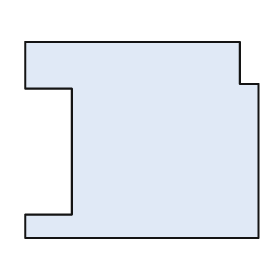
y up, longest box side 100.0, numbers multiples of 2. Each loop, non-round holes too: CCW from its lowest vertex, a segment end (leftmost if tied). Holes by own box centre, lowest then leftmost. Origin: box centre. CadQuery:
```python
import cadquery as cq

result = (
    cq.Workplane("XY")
    .moveTo(-50.0, -42.0)
    .lineTo(50.0, -42.0)
    .lineTo(50.0, 24.0)
    .lineTo(42.0, 24.0)
    .lineTo(42.0, 42.0)
    .lineTo(-50.0, 42.0)
    .lineTo(-50.0, 22.0)
    .lineTo(-30.0, 22.0)
    .lineTo(-30.0, -32.0)
    .lineTo(-50.0, -32.0)
    .close()
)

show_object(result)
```